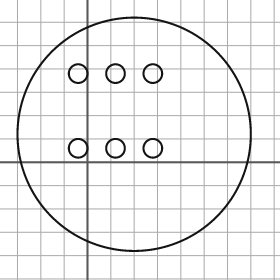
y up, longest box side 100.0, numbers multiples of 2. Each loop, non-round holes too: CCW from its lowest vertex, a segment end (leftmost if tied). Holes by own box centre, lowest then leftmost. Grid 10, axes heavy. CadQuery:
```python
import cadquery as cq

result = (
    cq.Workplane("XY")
    .moveTo(20.0, 12.0)
    .circle(50.0)
    .moveTo(-4.0, 6.0)
    .circle(4.0)
    .moveTo(12.0, 6.0)
    .circle(4.0)
    .moveTo(28.0, 6.0)
    .circle(4.0)
    .moveTo(-4.0, 38.0)
    .circle(4.0)
    .moveTo(12.0, 38.0)
    .circle(4.0)
    .moveTo(28.0, 38.0)
    .circle(4.0)
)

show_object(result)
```